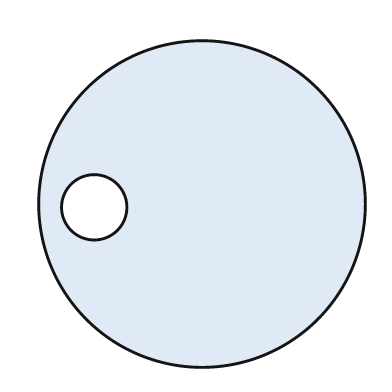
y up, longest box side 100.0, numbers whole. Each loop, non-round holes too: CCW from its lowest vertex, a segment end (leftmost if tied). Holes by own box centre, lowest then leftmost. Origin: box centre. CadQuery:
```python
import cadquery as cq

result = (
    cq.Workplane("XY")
    .moveTo(0.0, 0.0)
    .circle(50.0)
    .moveTo(-33.0, -1.0)
    .circle(10.0)
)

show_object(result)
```